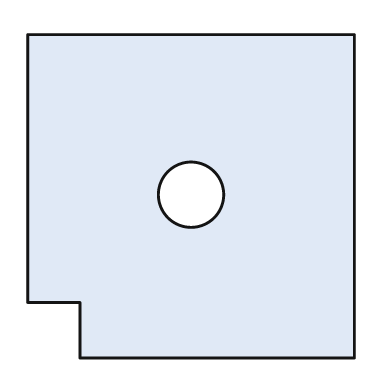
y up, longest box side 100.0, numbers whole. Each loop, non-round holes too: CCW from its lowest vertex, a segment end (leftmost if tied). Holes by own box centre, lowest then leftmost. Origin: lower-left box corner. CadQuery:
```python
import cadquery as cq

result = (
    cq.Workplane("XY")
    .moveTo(16.0, 0.0)
    .lineTo(100.0, 0.0)
    .lineTo(100.0, 99.0)
    .lineTo(0.0, 99.0)
    .lineTo(0.0, 17.0)
    .lineTo(16.0, 17.0)
    .close()
    .moveTo(50.0, 50.0)
    .circle(10.0)
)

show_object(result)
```